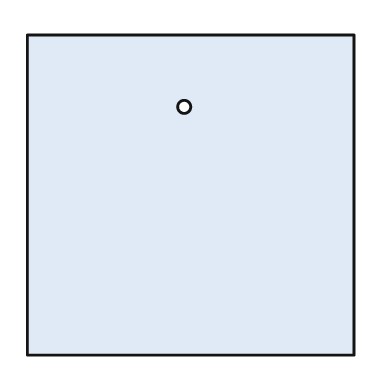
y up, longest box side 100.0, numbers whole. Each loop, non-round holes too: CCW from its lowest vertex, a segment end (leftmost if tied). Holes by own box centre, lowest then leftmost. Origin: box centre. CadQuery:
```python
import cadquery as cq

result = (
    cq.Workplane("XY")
    .moveTo(-50.0, -49.0)
    .lineTo(50.0, -49.0)
    .lineTo(50.0, 49.0)
    .lineTo(-50.0, 49.0)
    .close()
    .moveTo(-2.0, 27.0)
    .circle(2.0)
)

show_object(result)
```